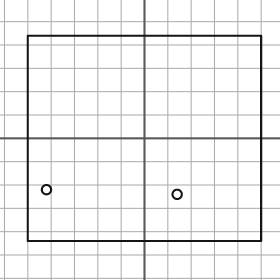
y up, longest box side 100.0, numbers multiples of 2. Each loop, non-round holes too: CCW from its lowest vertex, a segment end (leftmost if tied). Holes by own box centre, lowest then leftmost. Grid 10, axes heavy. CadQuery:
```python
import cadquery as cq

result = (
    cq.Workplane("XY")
    .moveTo(-50.0, -44.0)
    .lineTo(50.0, -44.0)
    .lineTo(50.0, 44.0)
    .lineTo(-50.0, 44.0)
    .close()
    .moveTo(14.0, -24.0)
    .circle(2.0)
    .moveTo(-42.0, -22.0)
    .circle(2.0)
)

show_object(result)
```